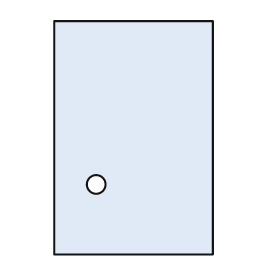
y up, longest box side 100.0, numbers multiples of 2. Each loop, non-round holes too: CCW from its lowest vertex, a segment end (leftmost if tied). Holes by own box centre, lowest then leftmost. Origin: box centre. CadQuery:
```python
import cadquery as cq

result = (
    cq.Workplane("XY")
    .moveTo(-34.0, -50.0)
    .lineTo(34.0, -50.0)
    .lineTo(34.0, 50.0)
    .lineTo(-34.0, 50.0)
    .close()
    .moveTo(-16.0, -20.0)
    .circle(4.0)
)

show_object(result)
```